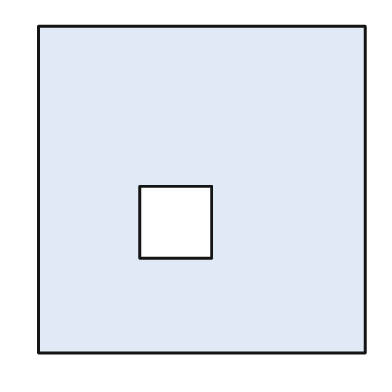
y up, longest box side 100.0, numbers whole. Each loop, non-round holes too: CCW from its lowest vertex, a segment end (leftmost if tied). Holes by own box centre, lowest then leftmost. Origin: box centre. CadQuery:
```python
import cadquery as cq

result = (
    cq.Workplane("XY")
    .moveTo(-50.0, -50.0)
    .lineTo(50.0, -50.0)
    .lineTo(50.0, 50.0)
    .lineTo(-50.0, 50.0)
    .close()
    .moveTo(-19.0, -21.0)
    .lineTo(3.0, -21.0)
    .lineTo(3.0, 1.0)
    .lineTo(-19.0, 1.0)
    .close()
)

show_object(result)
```